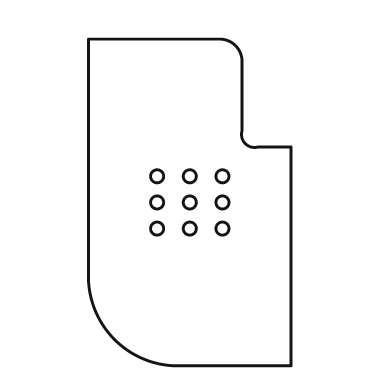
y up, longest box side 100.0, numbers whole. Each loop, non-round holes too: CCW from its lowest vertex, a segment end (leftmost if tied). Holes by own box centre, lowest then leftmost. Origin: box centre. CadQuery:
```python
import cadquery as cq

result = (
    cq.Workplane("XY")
    .moveTo(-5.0, -50.0)
    .lineTo(31.0, -50.0)
    .lineTo(31.0, 17.0)
    .lineTo(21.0, 17.0)
    .threePointArc((17.0, 18.0), (16.0, 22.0))
    .lineTo(16.0, 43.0)
    .threePointArc((14.0, 48.0), (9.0, 50.0))
    .lineTo(-31.0, 50.0)
    .lineTo(-31.0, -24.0)
    .threePointArc((-23.0, -42.0), (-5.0, -50.0))
    .close()
    .moveTo(-10.0, -8.0)
    .circle(2.0)
    .moveTo(0.0, -8.0)
    .circle(2.0)
    .moveTo(10.0, -8.0)
    .circle(2.0)
    .moveTo(-10.0, 0.0)
    .circle(2.0)
    .moveTo(0.0, 0.0)
    .circle(2.0)
    .moveTo(10.0, 0.0)
    .circle(2.0)
    .moveTo(-10.0, 8.0)
    .circle(2.0)
    .moveTo(0.0, 8.0)
    .circle(2.0)
    .moveTo(10.0, 8.0)
    .circle(2.0)
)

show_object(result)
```